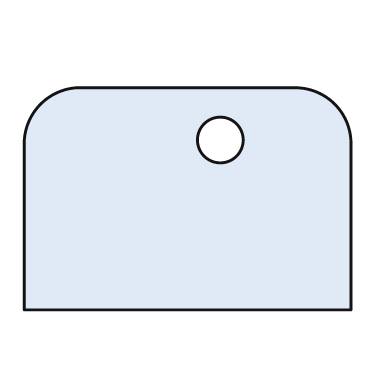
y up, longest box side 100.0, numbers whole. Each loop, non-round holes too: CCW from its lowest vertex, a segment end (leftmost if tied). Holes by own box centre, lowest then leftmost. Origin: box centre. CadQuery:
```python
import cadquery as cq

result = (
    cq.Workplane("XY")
    .moveTo(-50.0, -34.0)
    .lineTo(50.0, -34.0)
    .lineTo(50.0, 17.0)
    .threePointArc((45.0, 29.0), (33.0, 34.0))
    .lineTo(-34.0, 34.0)
    .threePointArc((-45.0, 29.0), (-50.0, 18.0))
    .close()
    .moveTo(10.0, 18.0)
    .circle(7.0)
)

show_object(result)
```